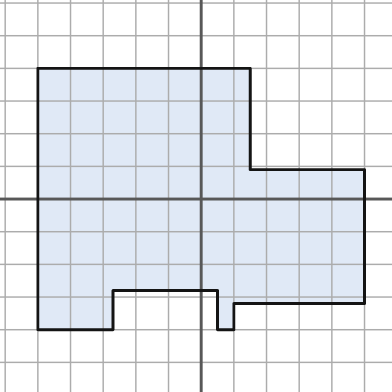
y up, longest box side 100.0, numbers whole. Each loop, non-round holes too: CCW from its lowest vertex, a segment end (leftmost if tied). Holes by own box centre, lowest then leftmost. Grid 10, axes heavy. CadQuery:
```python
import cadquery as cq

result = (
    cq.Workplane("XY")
    .moveTo(-50.0, -40.0)
    .lineTo(-27.0, -40.0)
    .lineTo(-27.0, -28.0)
    .lineTo(5.0, -28.0)
    .lineTo(5.0, -40.0)
    .lineTo(10.0, -40.0)
    .lineTo(10.0, -32.0)
    .lineTo(50.0, -32.0)
    .lineTo(50.0, 9.0)
    .lineTo(15.0, 9.0)
    .lineTo(15.0, 40.0)
    .lineTo(-50.0, 40.0)
    .close()
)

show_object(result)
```